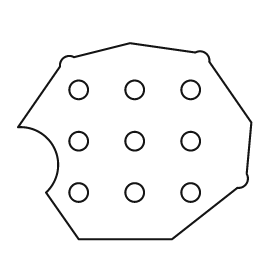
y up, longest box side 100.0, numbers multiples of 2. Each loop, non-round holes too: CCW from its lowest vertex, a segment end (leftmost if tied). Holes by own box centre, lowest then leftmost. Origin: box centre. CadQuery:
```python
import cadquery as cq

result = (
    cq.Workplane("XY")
    .moveTo(-24.0, -42.0)
    .lineTo(16.0, -42.0)
    .lineTo(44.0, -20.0)
    .threePointArc((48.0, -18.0), (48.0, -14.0))
    .lineTo(50.0, 8.0)
    .lineTo(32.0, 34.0)
    .threePointArc((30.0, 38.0), (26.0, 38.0))
    .lineTo(-2.0, 42.0)
    .lineTo(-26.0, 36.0)
    .threePointArc((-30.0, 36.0), (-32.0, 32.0))
    .lineTo(-50.0, 6.0)
    .threePointArc((-34.0, -4.0), (-38.0, -22.0))
    .close()
    .moveTo(-24.0, -22.0)
    .circle(4.0)
    .moveTo(0.0, -22.0)
    .circle(4.0)
    .moveTo(24.0, -22.0)
    .circle(4.0)
    .moveTo(-24.0, 0.0)
    .circle(4.0)
    .moveTo(0.0, 0.0)
    .circle(4.0)
    .moveTo(24.0, 0.0)
    .circle(4.0)
    .moveTo(-24.0, 22.0)
    .circle(4.0)
    .moveTo(0.0, 22.0)
    .circle(4.0)
    .moveTo(24.0, 22.0)
    .circle(4.0)
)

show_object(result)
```